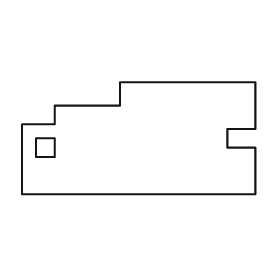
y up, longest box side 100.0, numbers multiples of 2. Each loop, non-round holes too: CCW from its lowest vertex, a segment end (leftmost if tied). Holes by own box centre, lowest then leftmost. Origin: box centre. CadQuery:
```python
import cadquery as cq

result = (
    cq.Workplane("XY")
    .moveTo(-50.0, -24.0)
    .lineTo(50.0, -24.0)
    .lineTo(50.0, -4.0)
    .lineTo(38.0, -4.0)
    .lineTo(38.0, 4.0)
    .lineTo(50.0, 4.0)
    .lineTo(50.0, 24.0)
    .lineTo(-8.0, 24.0)
    .lineTo(-8.0, 14.0)
    .lineTo(-36.0, 14.0)
    .lineTo(-36.0, 6.0)
    .lineTo(-50.0, 6.0)
    .close()
    .moveTo(-44.0, -8.0)
    .lineTo(-36.0, -8.0)
    .lineTo(-36.0, 0.0)
    .lineTo(-44.0, 0.0)
    .close()
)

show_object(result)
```